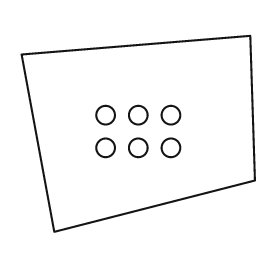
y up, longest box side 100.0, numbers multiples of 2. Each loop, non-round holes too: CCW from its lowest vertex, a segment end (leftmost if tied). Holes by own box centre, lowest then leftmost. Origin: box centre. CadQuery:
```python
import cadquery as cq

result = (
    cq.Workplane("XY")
    .moveTo(-36.0, -42.0)
    .lineTo(50.0, -20.0)
    .lineTo(48.0, 42.0)
    .lineTo(-50.0, 34.0)
    .close()
    .moveTo(-14.0, -6.0)
    .circle(4.0)
    .moveTo(0.0, -6.0)
    .circle(4.0)
    .moveTo(14.0, -6.0)
    .circle(4.0)
    .moveTo(-14.0, 8.0)
    .circle(4.0)
    .moveTo(0.0, 8.0)
    .circle(4.0)
    .moveTo(14.0, 8.0)
    .circle(4.0)
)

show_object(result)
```